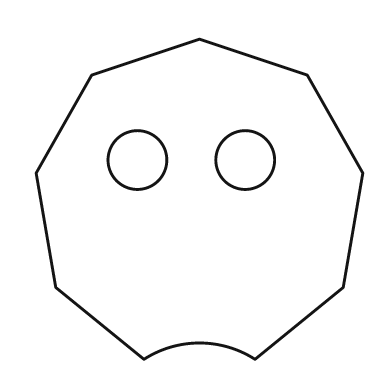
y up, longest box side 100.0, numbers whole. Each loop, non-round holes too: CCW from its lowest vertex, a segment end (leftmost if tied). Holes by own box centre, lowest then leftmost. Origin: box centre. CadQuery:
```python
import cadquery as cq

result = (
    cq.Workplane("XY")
    .moveTo(-17.0, -49.0)
    .threePointArc((0.0, -44.0), (17.0, -49.0))
    .lineTo(44.0, -27.0)
    .lineTo(50.0, 8.0)
    .lineTo(33.0, 38.0)
    .lineTo(0.0, 49.0)
    .lineTo(-33.0, 38.0)
    .lineTo(-50.0, 8.0)
    .lineTo(-44.0, -27.0)
    .close()
    .moveTo(-19.0, 12.0)
    .circle(9.0)
    .moveTo(14.0, 12.0)
    .circle(9.0)
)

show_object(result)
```